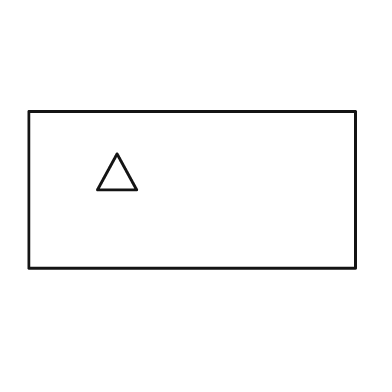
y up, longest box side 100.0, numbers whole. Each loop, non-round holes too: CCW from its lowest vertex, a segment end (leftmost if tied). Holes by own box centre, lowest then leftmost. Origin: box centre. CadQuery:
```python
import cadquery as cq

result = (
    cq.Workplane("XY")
    .moveTo(-50.0, -24.0)
    .lineTo(50.0, -24.0)
    .lineTo(50.0, 24.0)
    .lineTo(-50.0, 24.0)
    .close()
    .moveTo(-29.0, 0.0)
    .lineTo(-17.0, 0.0)
    .lineTo(-23.0, 11.0)
    .close()
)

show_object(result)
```